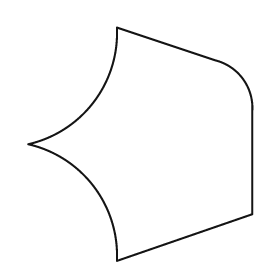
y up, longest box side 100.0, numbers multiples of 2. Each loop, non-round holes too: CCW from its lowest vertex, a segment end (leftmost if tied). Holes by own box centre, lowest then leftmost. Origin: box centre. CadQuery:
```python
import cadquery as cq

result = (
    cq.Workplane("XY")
    .moveTo(-10.0, -50.0)
    .lineTo(48.0, -30.0)
    .lineTo(48.0, 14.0)
    .threePointArc((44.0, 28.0), (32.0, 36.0))
    .lineTo(-10.0, 50.0)
    .threePointArc((-20.0, 18.0), (-48.0, 0.0))
    .threePointArc((-20.0, -18.0), (-10.0, -50.0))
    .close()
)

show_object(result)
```